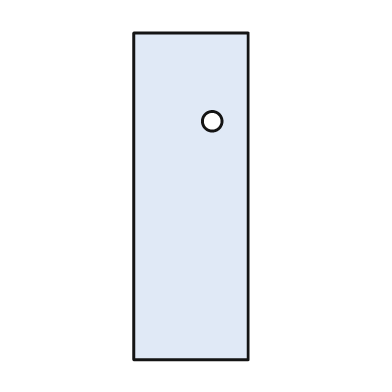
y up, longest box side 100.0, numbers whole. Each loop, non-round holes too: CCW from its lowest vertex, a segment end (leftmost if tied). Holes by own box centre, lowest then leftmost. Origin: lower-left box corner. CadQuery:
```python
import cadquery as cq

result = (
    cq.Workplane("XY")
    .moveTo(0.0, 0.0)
    .lineTo(35.0, 0.0)
    .lineTo(35.0, 100.0)
    .lineTo(0.0, 100.0)
    .close()
    .moveTo(24.0, 73.0)
    .circle(3.0)
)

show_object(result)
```